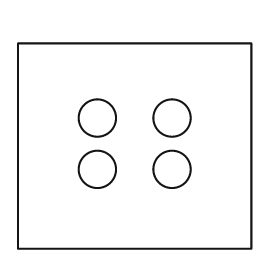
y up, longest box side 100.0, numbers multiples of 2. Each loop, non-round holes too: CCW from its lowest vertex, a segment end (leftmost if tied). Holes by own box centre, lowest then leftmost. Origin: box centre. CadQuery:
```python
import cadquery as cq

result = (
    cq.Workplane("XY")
    .moveTo(-50.0, -44.0)
    .lineTo(50.0, -44.0)
    .lineTo(50.0, 44.0)
    .lineTo(-50.0, 44.0)
    .close()
    .moveTo(-16.0, -10.0)
    .circle(8.0)
    .moveTo(16.0, -10.0)
    .circle(8.0)
    .moveTo(-16.0, 12.0)
    .circle(8.0)
    .moveTo(16.0, 12.0)
    .circle(8.0)
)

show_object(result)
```